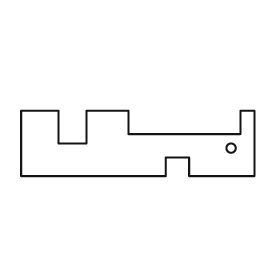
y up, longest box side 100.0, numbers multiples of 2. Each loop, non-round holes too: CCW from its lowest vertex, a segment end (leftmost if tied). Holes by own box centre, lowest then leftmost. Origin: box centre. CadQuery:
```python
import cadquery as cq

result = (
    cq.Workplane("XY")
    .moveTo(-50.0, -14.0)
    .lineTo(12.0, -14.0)
    .lineTo(12.0, -6.0)
    .lineTo(22.0, -6.0)
    .lineTo(22.0, -14.0)
    .lineTo(50.0, -14.0)
    .lineTo(50.0, 14.0)
    .lineTo(44.0, 14.0)
    .lineTo(44.0, 4.0)
    .lineTo(-4.0, 4.0)
    .lineTo(-4.0, 14.0)
    .lineTo(-22.0, 14.0)
    .lineTo(-22.0, 0.0)
    .lineTo(-34.0, 0.0)
    .lineTo(-34.0, 14.0)
    .lineTo(-50.0, 14.0)
    .close()
    .moveTo(40.0, -2.0)
    .circle(2.0)
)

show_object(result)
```